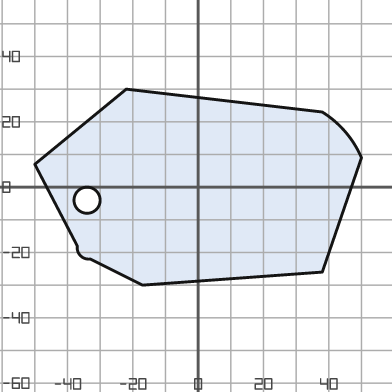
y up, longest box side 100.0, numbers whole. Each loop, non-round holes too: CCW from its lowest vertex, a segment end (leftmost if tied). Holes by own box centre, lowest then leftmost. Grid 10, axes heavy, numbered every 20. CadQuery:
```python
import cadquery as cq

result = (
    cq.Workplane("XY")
    .moveTo(-17.0, -30.0)
    .lineTo(38.0, -26.0)
    .lineTo(50.0, 9.0)
    .threePointArc((45.0, 17.0), (38.0, 23.0))
    .lineTo(-22.0, 30.0)
    .lineTo(-50.0, 7.0)
    .lineTo(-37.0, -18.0)
    .threePointArc((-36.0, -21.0), (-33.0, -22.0))
    .close()
    .moveTo(-34.0, -4.0)
    .circle(4.0)
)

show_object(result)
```